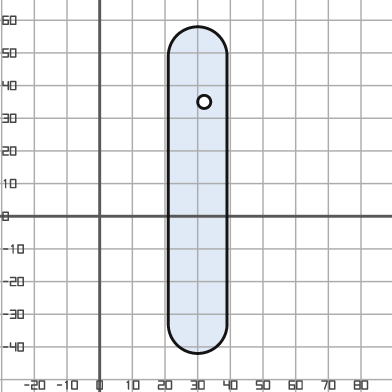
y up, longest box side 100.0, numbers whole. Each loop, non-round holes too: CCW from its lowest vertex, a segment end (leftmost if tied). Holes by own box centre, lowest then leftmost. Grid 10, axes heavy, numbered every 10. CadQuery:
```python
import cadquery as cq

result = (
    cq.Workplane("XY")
    .moveTo(21.0, -33.0)
    .threePointArc((30.0, -42.0), (39.0, -33.0))
    .lineTo(39.0, 49.0)
    .threePointArc((30.0, 58.0), (21.0, 49.0))
    .close()
    .moveTo(32.0, 35.0)
    .circle(2.0)
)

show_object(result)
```